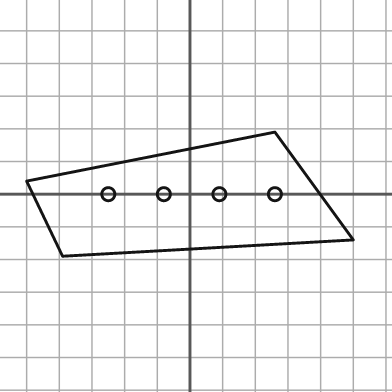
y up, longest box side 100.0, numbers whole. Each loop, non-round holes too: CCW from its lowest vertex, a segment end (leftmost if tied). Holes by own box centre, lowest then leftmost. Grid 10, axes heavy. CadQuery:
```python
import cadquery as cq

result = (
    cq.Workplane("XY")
    .moveTo(-39.0, -19.0)
    .lineTo(50.0, -14.0)
    .lineTo(26.0, 19.0)
    .lineTo(-50.0, 4.0)
    .close()
    .moveTo(-25.0, 0.0)
    .circle(2.0)
    .moveTo(-8.0, 0.0)
    .circle(2.0)
    .moveTo(9.0, 0.0)
    .circle(2.0)
    .moveTo(26.0, 0.0)
    .circle(2.0)
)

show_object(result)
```